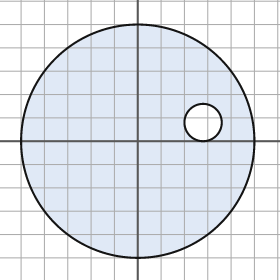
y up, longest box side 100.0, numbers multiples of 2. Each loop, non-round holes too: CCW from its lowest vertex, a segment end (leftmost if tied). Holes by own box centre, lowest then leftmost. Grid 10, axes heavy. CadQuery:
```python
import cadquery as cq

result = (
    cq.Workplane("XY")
    .moveTo(0.0, 0.0)
    .circle(50.0)
    .moveTo(28.0, 8.0)
    .circle(8.0)
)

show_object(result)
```